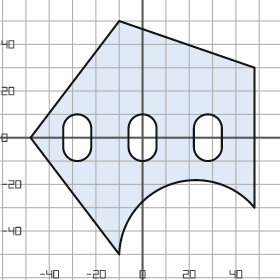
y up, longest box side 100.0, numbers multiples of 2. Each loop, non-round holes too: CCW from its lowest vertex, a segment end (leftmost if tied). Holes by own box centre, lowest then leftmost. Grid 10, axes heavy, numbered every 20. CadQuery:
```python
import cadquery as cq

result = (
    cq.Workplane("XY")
    .moveTo(-10.0, -50.0)
    .threePointArc((12.0, -20.0), (48.0, -30.0))
    .lineTo(48.0, 30.0)
    .lineTo(-10.0, 50.0)
    .lineTo(-48.0, 0.0)
    .close()
    .moveTo(-34.0, -4.0)
    .threePointArc((-28.0, -10.0), (-22.0, -4.0))
    .lineTo(-22.0, 4.0)
    .threePointArc((-28.0, 10.0), (-34.0, 4.0))
    .close()
    .moveTo(-6.0, -4.0)
    .threePointArc((0.0, -10.0), (6.0, -4.0))
    .lineTo(6.0, 4.0)
    .threePointArc((0.0, 10.0), (-6.0, 4.0))
    .close()
    .moveTo(22.0, -4.0)
    .threePointArc((28.0, -10.0), (34.0, -4.0))
    .lineTo(34.0, 4.0)
    .threePointArc((28.0, 10.0), (22.0, 4.0))
    .close()
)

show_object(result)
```